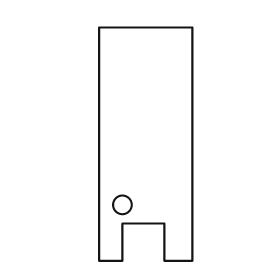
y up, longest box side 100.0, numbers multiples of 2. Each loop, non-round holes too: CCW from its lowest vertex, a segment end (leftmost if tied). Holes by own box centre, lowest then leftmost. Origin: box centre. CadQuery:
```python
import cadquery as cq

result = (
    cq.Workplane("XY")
    .moveTo(-20.0, -50.0)
    .lineTo(-10.0, -50.0)
    .lineTo(-10.0, -34.0)
    .lineTo(8.0, -34.0)
    .lineTo(8.0, -50.0)
    .lineTo(20.0, -50.0)
    .lineTo(20.0, 50.0)
    .lineTo(-20.0, 50.0)
    .close()
    .moveTo(-10.0, -26.0)
    .circle(4.0)
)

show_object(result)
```